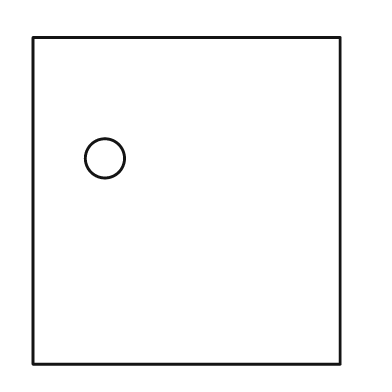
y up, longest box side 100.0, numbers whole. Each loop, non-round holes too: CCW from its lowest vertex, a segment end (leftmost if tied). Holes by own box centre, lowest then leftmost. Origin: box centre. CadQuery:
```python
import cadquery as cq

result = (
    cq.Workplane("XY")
    .moveTo(-47.0, -50.0)
    .lineTo(47.0, -50.0)
    .lineTo(47.0, 50.0)
    .lineTo(-47.0, 50.0)
    .close()
    .moveTo(-25.0, 13.0)
    .circle(6.0)
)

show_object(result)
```